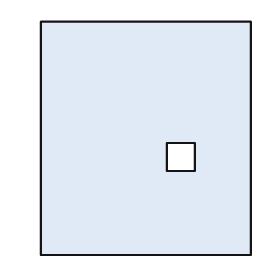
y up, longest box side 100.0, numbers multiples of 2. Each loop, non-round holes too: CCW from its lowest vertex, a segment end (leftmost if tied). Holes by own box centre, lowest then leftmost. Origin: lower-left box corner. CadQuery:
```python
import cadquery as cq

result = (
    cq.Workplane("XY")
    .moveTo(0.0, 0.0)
    .lineTo(90.0, 0.0)
    .lineTo(90.0, 100.0)
    .lineTo(0.0, 100.0)
    .close()
    .moveTo(54.0, 36.0)
    .lineTo(66.0, 36.0)
    .lineTo(66.0, 48.0)
    .lineTo(54.0, 48.0)
    .close()
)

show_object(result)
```